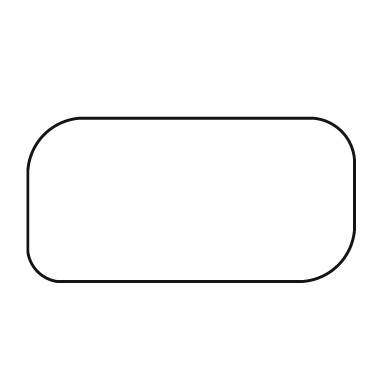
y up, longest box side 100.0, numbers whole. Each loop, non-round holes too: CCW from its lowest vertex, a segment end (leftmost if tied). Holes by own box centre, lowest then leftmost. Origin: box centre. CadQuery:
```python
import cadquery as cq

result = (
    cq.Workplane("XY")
    .moveTo(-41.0, -25.0)
    .lineTo(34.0, -25.0)
    .threePointArc((45.0, -20.0), (50.0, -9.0))
    .lineTo(50.0, 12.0)
    .threePointArc((46.0, 21.0), (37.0, 25.0))
    .lineTo(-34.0, 25.0)
    .threePointArc((-45.0, 20.0), (-50.0, 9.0))
    .lineTo(-50.0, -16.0)
    .threePointArc((-47.0, -22.0), (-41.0, -25.0))
    .close()
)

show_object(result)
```